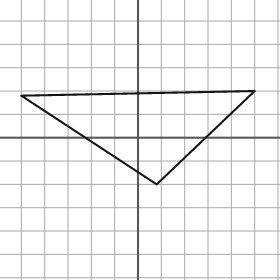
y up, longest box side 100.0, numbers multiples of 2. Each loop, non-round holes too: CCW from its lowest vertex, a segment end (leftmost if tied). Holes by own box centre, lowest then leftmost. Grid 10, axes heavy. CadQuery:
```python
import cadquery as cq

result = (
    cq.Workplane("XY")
    .moveTo(8.0, -20.0)
    .lineTo(50.0, 20.0)
    .lineTo(-50.0, 18.0)
    .close()
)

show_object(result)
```